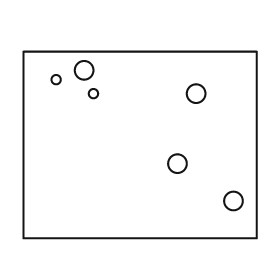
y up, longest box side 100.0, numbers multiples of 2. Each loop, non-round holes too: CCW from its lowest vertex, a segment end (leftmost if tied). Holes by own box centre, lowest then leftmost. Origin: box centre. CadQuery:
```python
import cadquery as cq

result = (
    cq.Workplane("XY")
    .moveTo(-50.0, -40.0)
    .lineTo(50.0, -40.0)
    .lineTo(50.0, 40.0)
    .lineTo(-50.0, 40.0)
    .close()
    .moveTo(40.0, -24.0)
    .circle(4.0)
    .moveTo(16.0, -8.0)
    .circle(4.0)
    .moveTo(-20.0, 22.0)
    .circle(2.0)
    .moveTo(24.0, 22.0)
    .circle(4.0)
    .moveTo(-36.0, 28.0)
    .circle(2.0)
    .moveTo(-24.0, 32.0)
    .circle(4.0)
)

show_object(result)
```